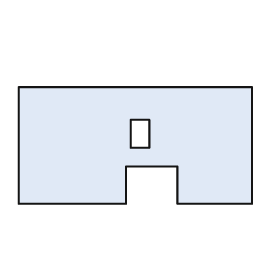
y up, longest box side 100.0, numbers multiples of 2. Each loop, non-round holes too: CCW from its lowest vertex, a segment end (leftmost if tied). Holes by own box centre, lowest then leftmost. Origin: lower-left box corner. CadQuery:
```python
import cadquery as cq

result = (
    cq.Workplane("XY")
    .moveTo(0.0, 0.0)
    .lineTo(46.0, 0.0)
    .lineTo(46.0, 16.0)
    .lineTo(68.0, 16.0)
    .lineTo(68.0, 0.0)
    .lineTo(100.0, 0.0)
    .lineTo(100.0, 50.0)
    .lineTo(0.0, 50.0)
    .close()
    .moveTo(48.0, 24.0)
    .lineTo(56.0, 24.0)
    .lineTo(56.0, 36.0)
    .lineTo(48.0, 36.0)
    .close()
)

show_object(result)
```